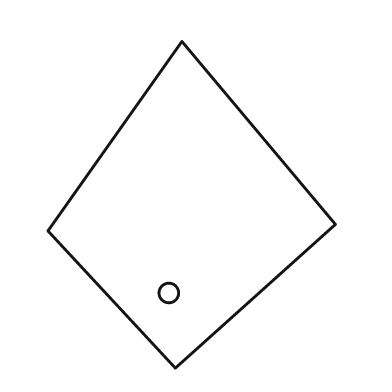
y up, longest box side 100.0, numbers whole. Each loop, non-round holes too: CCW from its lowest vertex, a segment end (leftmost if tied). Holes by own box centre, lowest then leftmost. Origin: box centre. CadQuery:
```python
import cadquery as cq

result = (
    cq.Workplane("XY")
    .moveTo(-5.0, -50.0)
    .lineTo(44.0, -6.0)
    .lineTo(-3.0, 50.0)
    .lineTo(-44.0, -8.0)
    .close()
    .moveTo(-7.0, -27.0)
    .circle(3.0)
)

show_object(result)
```